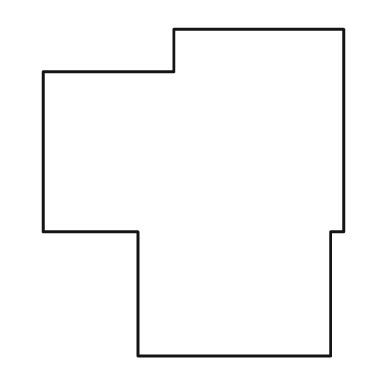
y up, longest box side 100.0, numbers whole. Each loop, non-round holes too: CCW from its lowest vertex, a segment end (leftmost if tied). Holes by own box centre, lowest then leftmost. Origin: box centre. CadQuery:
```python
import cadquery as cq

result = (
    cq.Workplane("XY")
    .moveTo(-17.0, -50.0)
    .lineTo(42.0, -50.0)
    .lineTo(42.0, -12.0)
    .lineTo(46.0, -12.0)
    .lineTo(46.0, 50.0)
    .lineTo(-6.0, 50.0)
    .lineTo(-6.0, 37.0)
    .lineTo(-46.0, 37.0)
    .lineTo(-46.0, -12.0)
    .lineTo(-17.0, -12.0)
    .close()
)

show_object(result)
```